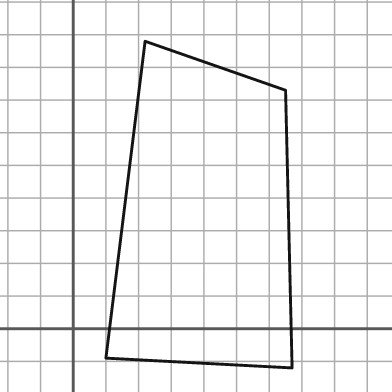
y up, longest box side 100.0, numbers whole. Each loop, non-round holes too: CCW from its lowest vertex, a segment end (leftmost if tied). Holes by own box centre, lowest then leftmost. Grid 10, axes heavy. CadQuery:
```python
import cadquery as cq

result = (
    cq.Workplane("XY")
    .moveTo(67.0, -12.0)
    .lineTo(65.0, 73.0)
    .lineTo(22.0, 88.0)
    .lineTo(10.0, -9.0)
    .close()
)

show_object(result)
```